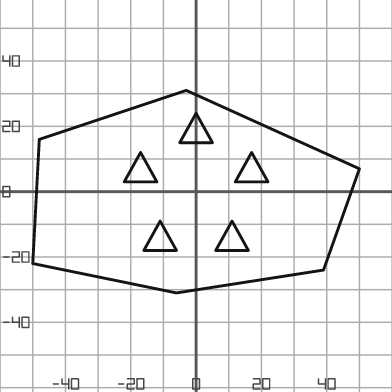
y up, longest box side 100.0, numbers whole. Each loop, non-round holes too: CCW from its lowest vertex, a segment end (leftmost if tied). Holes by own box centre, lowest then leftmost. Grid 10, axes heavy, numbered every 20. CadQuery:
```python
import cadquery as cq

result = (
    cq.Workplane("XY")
    .moveTo(-6.0, -31.0)
    .lineTo(39.0, -24.0)
    .lineTo(50.0, 7.0)
    .lineTo(-3.0, 31.0)
    .lineTo(-48.0, 16.0)
    .lineTo(-50.0, -22.0)
    .close()
    .moveTo(-16.0, -18.0)
    .lineTo(-6.0, -18.0)
    .lineTo(-11.0, -9.0)
    .close()
    .moveTo(6.0, -18.0)
    .lineTo(16.0, -18.0)
    .lineTo(11.0, -9.0)
    .close()
    .moveTo(-22.0, 3.0)
    .lineTo(-12.0, 3.0)
    .lineTo(-17.0, 12.0)
    .close()
    .moveTo(12.0, 3.0)
    .lineTo(22.0, 3.0)
    .lineTo(17.0, 12.0)
    .close()
    .moveTo(-5.0, 15.0)
    .lineTo(5.0, 15.0)
    .lineTo(0.0, 24.0)
    .close()
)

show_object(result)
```